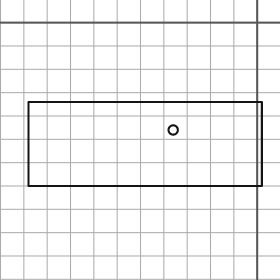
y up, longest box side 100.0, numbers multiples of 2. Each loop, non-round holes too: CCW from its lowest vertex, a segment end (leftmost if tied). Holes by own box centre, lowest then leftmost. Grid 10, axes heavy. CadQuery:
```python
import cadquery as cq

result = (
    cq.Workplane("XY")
    .moveTo(-98.0, -70.0)
    .lineTo(2.0, -70.0)
    .lineTo(2.0, -34.0)
    .lineTo(-98.0, -34.0)
    .close()
    .moveTo(-36.0, -46.0)
    .circle(2.0)
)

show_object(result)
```